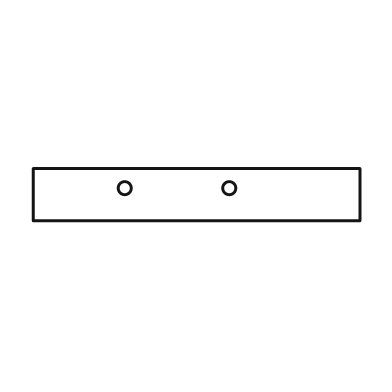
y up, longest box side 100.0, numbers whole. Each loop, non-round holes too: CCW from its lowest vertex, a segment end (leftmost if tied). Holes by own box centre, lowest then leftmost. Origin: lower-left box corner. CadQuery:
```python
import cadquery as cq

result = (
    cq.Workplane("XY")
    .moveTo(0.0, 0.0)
    .lineTo(100.0, 0.0)
    .lineTo(100.0, 16.0)
    .lineTo(0.0, 16.0)
    .close()
    .moveTo(28.0, 10.0)
    .circle(2.0)
    .moveTo(60.0, 10.0)
    .circle(2.0)
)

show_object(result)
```